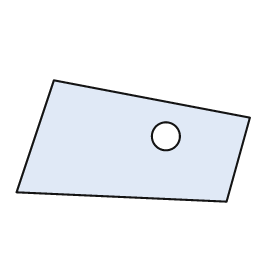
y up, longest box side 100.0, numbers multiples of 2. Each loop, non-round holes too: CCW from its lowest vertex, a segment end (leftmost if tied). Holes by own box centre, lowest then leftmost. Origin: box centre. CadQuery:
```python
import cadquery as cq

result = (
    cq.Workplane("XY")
    .moveTo(40.0, -26.0)
    .lineTo(50.0, 10.0)
    .lineTo(-34.0, 26.0)
    .lineTo(-50.0, -22.0)
    .close()
    .moveTo(14.0, 2.0)
    .circle(6.0)
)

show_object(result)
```